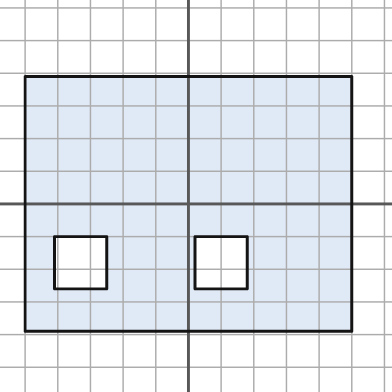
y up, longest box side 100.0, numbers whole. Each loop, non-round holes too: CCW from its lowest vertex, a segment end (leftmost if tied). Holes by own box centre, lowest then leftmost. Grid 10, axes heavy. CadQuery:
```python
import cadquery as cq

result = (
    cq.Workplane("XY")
    .moveTo(-50.0, -39.0)
    .lineTo(50.0, -39.0)
    .lineTo(50.0, 39.0)
    .lineTo(-50.0, 39.0)
    .close()
    .moveTo(-41.0, -26.0)
    .lineTo(-25.0, -26.0)
    .lineTo(-25.0, -10.0)
    .lineTo(-41.0, -10.0)
    .close()
    .moveTo(2.0, -26.0)
    .lineTo(18.0, -26.0)
    .lineTo(18.0, -10.0)
    .lineTo(2.0, -10.0)
    .close()
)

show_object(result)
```